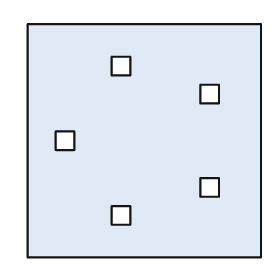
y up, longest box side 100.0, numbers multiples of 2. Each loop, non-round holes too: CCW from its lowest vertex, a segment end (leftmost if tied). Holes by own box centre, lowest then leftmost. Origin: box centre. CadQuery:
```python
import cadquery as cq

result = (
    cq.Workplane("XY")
    .moveTo(-50.0, -50.0)
    .lineTo(50.0, -50.0)
    .lineTo(50.0, 50.0)
    .lineTo(-50.0, 50.0)
    .close()
    .moveTo(-14.0, -36.0)
    .lineTo(-6.0, -36.0)
    .lineTo(-6.0, -28.0)
    .lineTo(-14.0, -28.0)
    .close()
    .moveTo(24.0, -24.0)
    .lineTo(32.0, -24.0)
    .lineTo(32.0, -16.0)
    .lineTo(24.0, -16.0)
    .close()
    .moveTo(-38.0, -4.0)
    .lineTo(-30.0, -4.0)
    .lineTo(-30.0, 4.0)
    .lineTo(-38.0, 4.0)
    .close()
    .moveTo(24.0, 16.0)
    .lineTo(32.0, 16.0)
    .lineTo(32.0, 24.0)
    .lineTo(24.0, 24.0)
    .close()
    .moveTo(-14.0, 28.0)
    .lineTo(-6.0, 28.0)
    .lineTo(-6.0, 36.0)
    .lineTo(-14.0, 36.0)
    .close()
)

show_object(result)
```